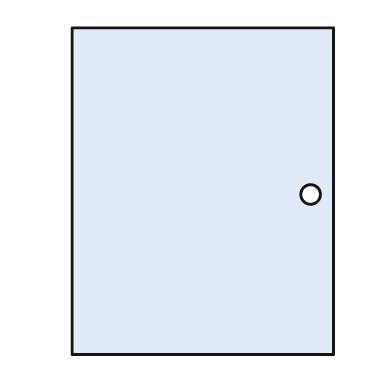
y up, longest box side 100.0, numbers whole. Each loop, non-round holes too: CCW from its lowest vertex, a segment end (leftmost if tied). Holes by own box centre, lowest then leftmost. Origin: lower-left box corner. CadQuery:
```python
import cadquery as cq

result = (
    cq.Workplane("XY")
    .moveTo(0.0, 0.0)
    .lineTo(80.0, 0.0)
    .lineTo(80.0, 100.0)
    .lineTo(0.0, 100.0)
    .close()
    .moveTo(73.0, 49.0)
    .circle(3.0)
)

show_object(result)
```